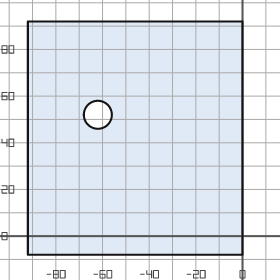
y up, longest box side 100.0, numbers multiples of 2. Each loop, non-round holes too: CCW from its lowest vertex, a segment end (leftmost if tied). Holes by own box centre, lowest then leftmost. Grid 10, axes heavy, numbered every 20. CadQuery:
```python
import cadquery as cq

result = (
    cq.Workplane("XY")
    .moveTo(-92.0, -8.0)
    .lineTo(0.0, -8.0)
    .lineTo(0.0, 92.0)
    .lineTo(-92.0, 92.0)
    .close()
    .moveTo(-62.0, 52.0)
    .circle(6.0)
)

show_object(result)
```